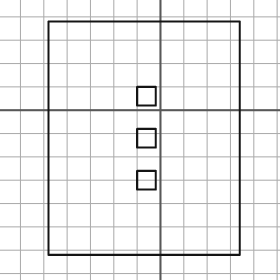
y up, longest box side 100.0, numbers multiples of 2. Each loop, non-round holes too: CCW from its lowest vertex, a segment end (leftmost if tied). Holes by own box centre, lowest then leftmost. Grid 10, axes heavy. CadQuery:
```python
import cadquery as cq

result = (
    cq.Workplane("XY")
    .moveTo(-48.0, -62.0)
    .lineTo(34.0, -62.0)
    .lineTo(34.0, 38.0)
    .lineTo(-48.0, 38.0)
    .close()
    .moveTo(-10.0, -34.0)
    .lineTo(-2.0, -34.0)
    .lineTo(-2.0, -26.0)
    .lineTo(-10.0, -26.0)
    .close()
    .moveTo(-10.0, -16.0)
    .lineTo(-2.0, -16.0)
    .lineTo(-2.0, -8.0)
    .lineTo(-10.0, -8.0)
    .close()
    .moveTo(-10.0, 2.0)
    .lineTo(-2.0, 2.0)
    .lineTo(-2.0, 10.0)
    .lineTo(-10.0, 10.0)
    .close()
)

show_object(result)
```